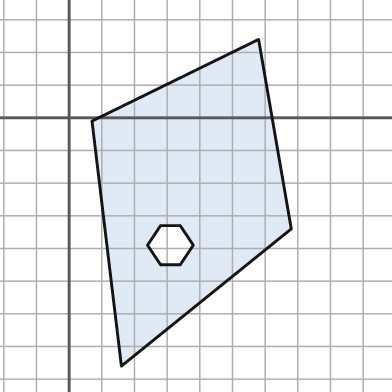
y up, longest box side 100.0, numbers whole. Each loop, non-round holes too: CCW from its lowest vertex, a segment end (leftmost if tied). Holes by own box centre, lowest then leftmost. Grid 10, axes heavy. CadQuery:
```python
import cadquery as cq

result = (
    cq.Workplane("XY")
    .moveTo(16.0, -76.0)
    .lineTo(68.0, -34.0)
    .lineTo(58.0, 24.0)
    .lineTo(7.0, -1.0)
    .close()
    .moveTo(28.0, -45.0)
    .lineTo(34.0, -45.0)
    .lineTo(38.0, -39.0)
    .lineTo(34.0, -33.0)
    .lineTo(28.0, -33.0)
    .lineTo(24.0, -39.0)
    .close()
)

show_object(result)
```